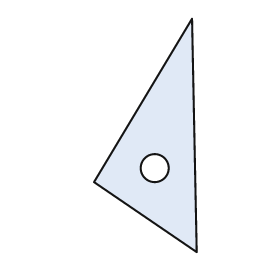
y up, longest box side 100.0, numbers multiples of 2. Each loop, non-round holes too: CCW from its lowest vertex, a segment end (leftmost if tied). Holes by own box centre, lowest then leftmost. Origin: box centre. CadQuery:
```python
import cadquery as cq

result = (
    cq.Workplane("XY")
    .moveTo(22.0, -50.0)
    .lineTo(20.0, 50.0)
    .lineTo(-22.0, -20.0)
    .close()
    .moveTo(4.0, -14.0)
    .circle(6.0)
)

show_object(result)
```